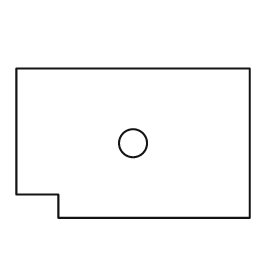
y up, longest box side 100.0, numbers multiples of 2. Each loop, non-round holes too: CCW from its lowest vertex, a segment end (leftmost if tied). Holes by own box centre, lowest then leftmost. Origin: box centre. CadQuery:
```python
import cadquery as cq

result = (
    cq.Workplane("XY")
    .moveTo(-32.0, -32.0)
    .lineTo(50.0, -32.0)
    .lineTo(50.0, 32.0)
    .lineTo(-50.0, 32.0)
    .lineTo(-50.0, -22.0)
    .lineTo(-32.0, -22.0)
    .close()
    .moveTo(0.0, 0.0)
    .circle(6.0)
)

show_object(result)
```